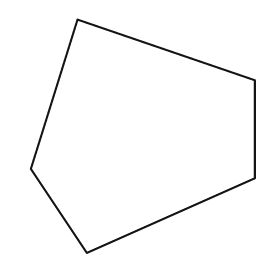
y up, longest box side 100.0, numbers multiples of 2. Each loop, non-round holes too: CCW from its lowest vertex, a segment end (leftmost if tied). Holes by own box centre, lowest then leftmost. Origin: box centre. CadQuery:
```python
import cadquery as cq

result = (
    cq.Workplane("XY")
    .moveTo(-24.0, -50.0)
    .lineTo(48.0, -18.0)
    .lineTo(48.0, 24.0)
    .lineTo(-28.0, 50.0)
    .lineTo(-48.0, -14.0)
    .close()
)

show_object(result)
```